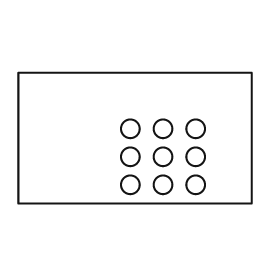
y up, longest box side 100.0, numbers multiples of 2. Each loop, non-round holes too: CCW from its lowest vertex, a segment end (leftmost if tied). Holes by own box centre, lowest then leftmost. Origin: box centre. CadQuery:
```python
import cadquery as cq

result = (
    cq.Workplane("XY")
    .moveTo(-50.0, -28.0)
    .lineTo(50.0, -28.0)
    .lineTo(50.0, 28.0)
    .lineTo(-50.0, 28.0)
    .close()
    .moveTo(-2.0, -20.0)
    .circle(4.0)
    .moveTo(12.0, -20.0)
    .circle(4.0)
    .moveTo(26.0, -20.0)
    .circle(4.0)
    .moveTo(-2.0, -8.0)
    .circle(4.0)
    .moveTo(12.0, -8.0)
    .circle(4.0)
    .moveTo(26.0, -8.0)
    .circle(4.0)
    .moveTo(-2.0, 4.0)
    .circle(4.0)
    .moveTo(12.0, 4.0)
    .circle(4.0)
    .moveTo(26.0, 4.0)
    .circle(4.0)
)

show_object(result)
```